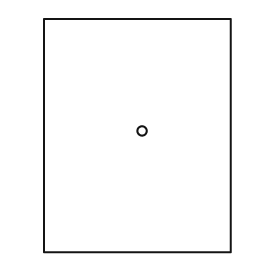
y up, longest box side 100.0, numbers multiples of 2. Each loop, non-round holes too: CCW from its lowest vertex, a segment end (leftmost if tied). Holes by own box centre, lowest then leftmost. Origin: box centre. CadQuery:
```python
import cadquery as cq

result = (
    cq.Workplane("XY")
    .moveTo(-40.0, -50.0)
    .lineTo(40.0, -50.0)
    .lineTo(40.0, 50.0)
    .lineTo(-40.0, 50.0)
    .close()
    .moveTo(2.0, 2.0)
    .circle(2.0)
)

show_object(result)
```